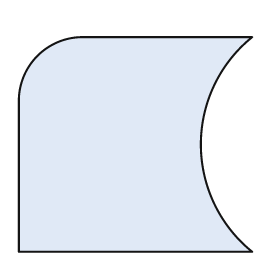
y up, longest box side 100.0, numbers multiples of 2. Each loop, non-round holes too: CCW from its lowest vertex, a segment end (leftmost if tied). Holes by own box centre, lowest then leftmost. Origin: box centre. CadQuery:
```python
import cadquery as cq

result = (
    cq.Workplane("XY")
    .moveTo(-50.0, -46.0)
    .lineTo(50.0, -46.0)
    .threePointArc((28.0, 0.0), (50.0, 46.0))
    .lineTo(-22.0, 46.0)
    .threePointArc((-42.0, 38.0), (-50.0, 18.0))
    .close()
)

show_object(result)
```